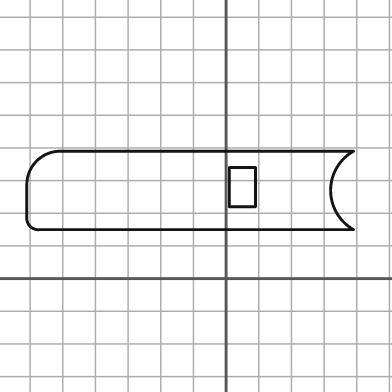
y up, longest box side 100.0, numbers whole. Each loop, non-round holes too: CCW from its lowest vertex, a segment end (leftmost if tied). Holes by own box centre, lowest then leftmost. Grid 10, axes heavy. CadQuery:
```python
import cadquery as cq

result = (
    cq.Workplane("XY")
    .moveTo(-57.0, 15.0)
    .lineTo(39.0, 15.0)
    .threePointArc((32.0, 27.0), (39.0, 39.0))
    .lineTo(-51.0, 39.0)
    .threePointArc((-58.0, 36.0), (-61.0, 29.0))
    .lineTo(-61.0, 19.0)
    .threePointArc((-60.0, 16.0), (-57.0, 15.0))
    .close()
    .moveTo(1.0, 22.0)
    .lineTo(9.0, 22.0)
    .lineTo(9.0, 34.0)
    .lineTo(1.0, 34.0)
    .close()
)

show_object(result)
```